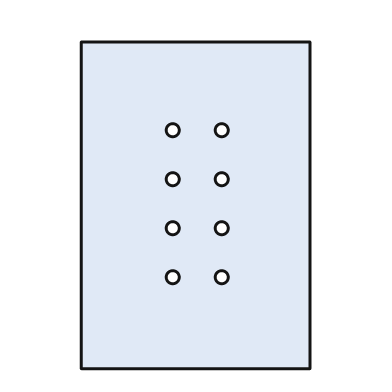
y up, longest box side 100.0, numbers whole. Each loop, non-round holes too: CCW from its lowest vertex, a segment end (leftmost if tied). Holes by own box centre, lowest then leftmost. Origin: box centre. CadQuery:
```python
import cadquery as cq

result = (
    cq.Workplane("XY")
    .moveTo(-35.0, -50.0)
    .lineTo(35.0, -50.0)
    .lineTo(35.0, 50.0)
    .lineTo(-35.0, 50.0)
    .close()
    .moveTo(-7.0, -22.0)
    .circle(2.0)
    .moveTo(8.0, -22.0)
    .circle(2.0)
    .moveTo(-7.0, -7.0)
    .circle(2.0)
    .moveTo(8.0, -7.0)
    .circle(2.0)
    .moveTo(-7.0, 8.0)
    .circle(2.0)
    .moveTo(8.0, 8.0)
    .circle(2.0)
    .moveTo(-7.0, 23.0)
    .circle(2.0)
    .moveTo(8.0, 23.0)
    .circle(2.0)
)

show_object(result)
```